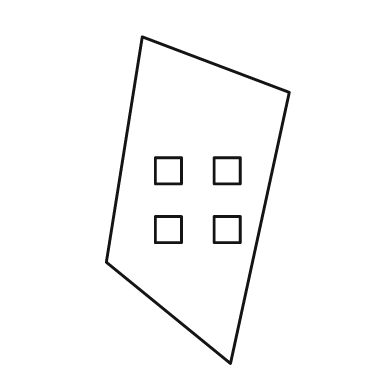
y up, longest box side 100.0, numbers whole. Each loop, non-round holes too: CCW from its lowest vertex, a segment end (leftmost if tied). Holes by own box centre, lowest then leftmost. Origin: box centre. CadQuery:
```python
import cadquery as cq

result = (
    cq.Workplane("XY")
    .moveTo(10.0, -50.0)
    .lineTo(28.0, 33.0)
    .lineTo(-17.0, 50.0)
    .lineTo(-28.0, -19.0)
    .close()
    .moveTo(-13.0, -13.0)
    .lineTo(-5.0, -13.0)
    .lineTo(-5.0, -5.0)
    .lineTo(-13.0, -5.0)
    .close()
    .moveTo(5.0, -13.0)
    .lineTo(13.0, -13.0)
    .lineTo(13.0, -5.0)
    .lineTo(5.0, -5.0)
    .close()
    .moveTo(-13.0, 5.0)
    .lineTo(-5.0, 5.0)
    .lineTo(-5.0, 13.0)
    .lineTo(-13.0, 13.0)
    .close()
    .moveTo(5.0, 5.0)
    .lineTo(13.0, 5.0)
    .lineTo(13.0, 13.0)
    .lineTo(5.0, 13.0)
    .close()
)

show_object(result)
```